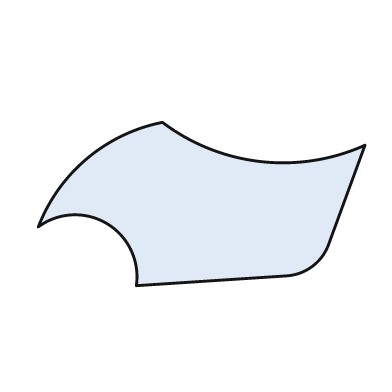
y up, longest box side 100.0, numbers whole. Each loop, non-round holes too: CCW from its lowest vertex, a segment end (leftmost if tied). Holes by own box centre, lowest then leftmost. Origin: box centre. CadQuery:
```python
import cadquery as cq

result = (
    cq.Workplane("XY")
    .moveTo(-20.0, -25.0)
    .lineTo(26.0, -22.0)
    .threePointArc((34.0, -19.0), (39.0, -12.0))
    .lineTo(50.0, 18.0)
    .threePointArc((18.0, 13.0), (-12.0, 25.0))
    .threePointArc((-35.0, 14.0), (-50.0, -7.0))
    .threePointArc((-29.0, -6.0), (-20.0, -25.0))
    .close()
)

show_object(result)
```